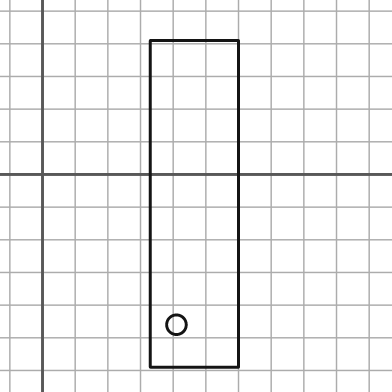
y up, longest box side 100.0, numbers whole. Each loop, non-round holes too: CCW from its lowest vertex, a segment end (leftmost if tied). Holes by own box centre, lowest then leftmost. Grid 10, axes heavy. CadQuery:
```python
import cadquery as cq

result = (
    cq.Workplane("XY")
    .moveTo(33.0, -59.0)
    .lineTo(60.0, -59.0)
    .lineTo(60.0, 41.0)
    .lineTo(33.0, 41.0)
    .close()
    .moveTo(41.0, -46.0)
    .circle(3.0)
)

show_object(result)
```